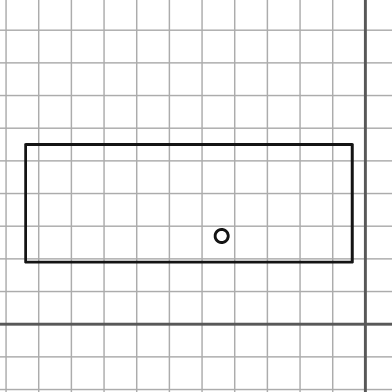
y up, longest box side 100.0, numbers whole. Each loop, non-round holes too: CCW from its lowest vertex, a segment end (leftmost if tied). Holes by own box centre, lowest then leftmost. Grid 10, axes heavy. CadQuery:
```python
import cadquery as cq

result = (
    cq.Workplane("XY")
    .moveTo(-104.0, 19.0)
    .lineTo(-4.0, 19.0)
    .lineTo(-4.0, 55.0)
    .lineTo(-104.0, 55.0)
    .close()
    .moveTo(-44.0, 27.0)
    .circle(2.0)
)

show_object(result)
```